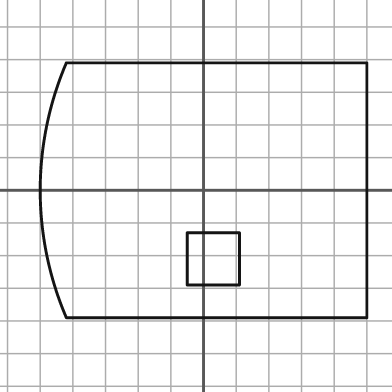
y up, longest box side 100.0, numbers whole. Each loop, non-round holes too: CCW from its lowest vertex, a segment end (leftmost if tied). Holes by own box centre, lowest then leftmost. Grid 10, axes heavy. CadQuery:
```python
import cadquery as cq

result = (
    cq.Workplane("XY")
    .moveTo(-42.0, -39.0)
    .lineTo(50.0, -39.0)
    .lineTo(50.0, 39.0)
    .lineTo(-42.0, 39.0)
    .threePointArc((-50.0, 0.0), (-42.0, -39.0))
    .close()
    .moveTo(-5.0, -29.0)
    .lineTo(11.0, -29.0)
    .lineTo(11.0, -13.0)
    .lineTo(-5.0, -13.0)
    .close()
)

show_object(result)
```